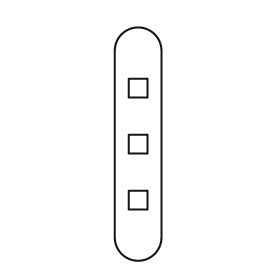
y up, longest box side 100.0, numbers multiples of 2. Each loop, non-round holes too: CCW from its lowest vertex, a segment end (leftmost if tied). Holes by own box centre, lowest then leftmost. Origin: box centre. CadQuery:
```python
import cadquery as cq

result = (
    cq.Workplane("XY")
    .moveTo(-10.0, -40.0)
    .threePointArc((0.0, -50.0), (10.0, -40.0))
    .lineTo(10.0, 40.0)
    .threePointArc((0.0, 50.0), (-10.0, 40.0))
    .close()
    .moveTo(-4.0, -28.0)
    .lineTo(4.0, -28.0)
    .lineTo(4.0, -20.0)
    .lineTo(-4.0, -20.0)
    .close()
    .moveTo(-4.0, -4.0)
    .lineTo(4.0, -4.0)
    .lineTo(4.0, 4.0)
    .lineTo(-4.0, 4.0)
    .close()
    .moveTo(-4.0, 20.0)
    .lineTo(4.0, 20.0)
    .lineTo(4.0, 28.0)
    .lineTo(-4.0, 28.0)
    .close()
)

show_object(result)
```